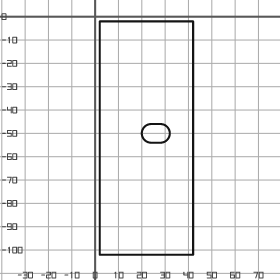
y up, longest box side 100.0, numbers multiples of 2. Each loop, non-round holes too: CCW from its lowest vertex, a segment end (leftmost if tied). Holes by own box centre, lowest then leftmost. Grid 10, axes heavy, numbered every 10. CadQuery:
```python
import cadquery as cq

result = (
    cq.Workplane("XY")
    .moveTo(2.0, -102.0)
    .lineTo(42.0, -102.0)
    .lineTo(42.0, -2.0)
    .lineTo(2.0, -2.0)
    .close()
    .moveTo(24.0, -54.0)
    .lineTo(28.0, -54.0)
    .threePointArc((32.0, -50.0), (28.0, -46.0))
    .lineTo(24.0, -46.0)
    .threePointArc((20.0, -50.0), (24.0, -54.0))
    .close()
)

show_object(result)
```